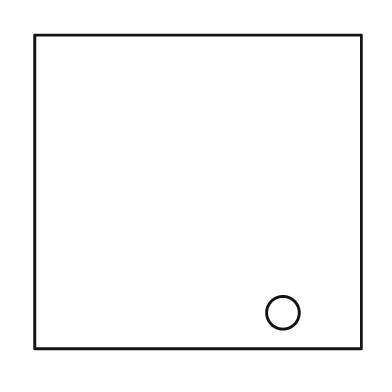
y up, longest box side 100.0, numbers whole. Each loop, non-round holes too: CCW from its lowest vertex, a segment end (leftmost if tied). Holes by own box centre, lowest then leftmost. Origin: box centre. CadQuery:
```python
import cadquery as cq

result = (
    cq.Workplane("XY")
    .moveTo(-50.0, -48.0)
    .lineTo(50.0, -48.0)
    .lineTo(50.0, 48.0)
    .lineTo(-50.0, 48.0)
    .close()
    .moveTo(26.0, -37.0)
    .circle(5.0)
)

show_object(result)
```